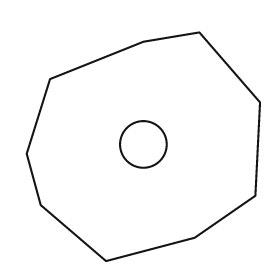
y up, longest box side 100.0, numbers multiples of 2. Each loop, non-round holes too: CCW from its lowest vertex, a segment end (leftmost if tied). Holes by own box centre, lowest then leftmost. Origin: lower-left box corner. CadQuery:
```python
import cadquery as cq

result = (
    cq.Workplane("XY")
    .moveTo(34.0, 0.0)
    .lineTo(72.0, 10.0)
    .lineTo(98.0, 28.0)
    .lineTo(100.0, 68.0)
    .lineTo(74.0, 98.0)
    .lineTo(50.0, 94.0)
    .lineTo(10.0, 78.0)
    .lineTo(0.0, 46.0)
    .lineTo(6.0, 24.0)
    .close()
    .moveTo(50.0, 50.0)
    .circle(10.0)
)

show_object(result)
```